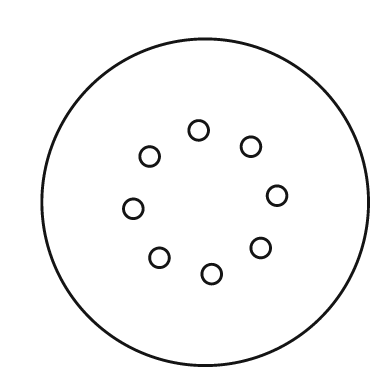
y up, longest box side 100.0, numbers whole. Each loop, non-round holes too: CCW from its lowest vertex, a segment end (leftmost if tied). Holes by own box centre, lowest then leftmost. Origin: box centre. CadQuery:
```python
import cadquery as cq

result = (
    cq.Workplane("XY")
    .moveTo(0.0, 0.0)
    .circle(50.0)
    .moveTo(2.0, -22.0)
    .circle(3.0)
    .moveTo(-14.0, -17.0)
    .circle(3.0)
    .moveTo(17.0, -14.0)
    .circle(3.0)
    .moveTo(-22.0, -2.0)
    .circle(3.0)
    .moveTo(22.0, 2.0)
    .circle(3.0)
    .moveTo(-17.0, 14.0)
    .circle(3.0)
    .moveTo(14.0, 17.0)
    .circle(3.0)
    .moveTo(-2.0, 22.0)
    .circle(3.0)
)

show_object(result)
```